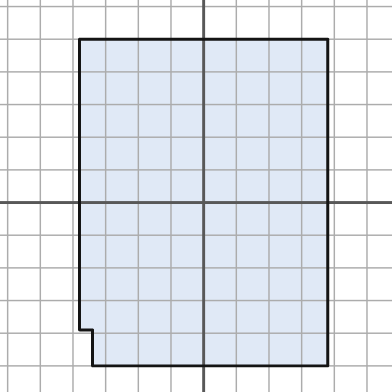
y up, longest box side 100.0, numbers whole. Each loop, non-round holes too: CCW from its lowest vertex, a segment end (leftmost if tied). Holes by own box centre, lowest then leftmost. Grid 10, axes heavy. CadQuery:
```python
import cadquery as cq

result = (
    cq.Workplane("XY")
    .moveTo(-34.0, -50.0)
    .lineTo(38.0, -50.0)
    .lineTo(38.0, 50.0)
    .lineTo(-38.0, 50.0)
    .lineTo(-38.0, -39.0)
    .lineTo(-34.0, -39.0)
    .close()
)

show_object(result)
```